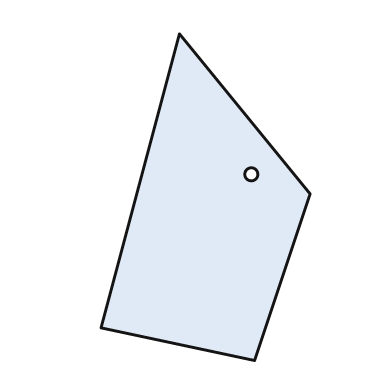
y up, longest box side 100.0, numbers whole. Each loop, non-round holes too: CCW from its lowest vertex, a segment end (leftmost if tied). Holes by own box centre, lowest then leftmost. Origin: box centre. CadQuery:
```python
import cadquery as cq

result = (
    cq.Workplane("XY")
    .moveTo(15.0, -50.0)
    .lineTo(32.0, 1.0)
    .lineTo(-8.0, 50.0)
    .lineTo(-32.0, -40.0)
    .close()
    .moveTo(14.0, 7.0)
    .circle(2.0)
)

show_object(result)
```